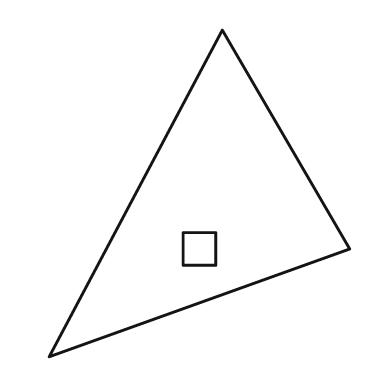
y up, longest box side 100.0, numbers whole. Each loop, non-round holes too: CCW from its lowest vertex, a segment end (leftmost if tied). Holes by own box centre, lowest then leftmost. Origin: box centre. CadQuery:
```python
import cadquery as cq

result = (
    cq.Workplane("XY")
    .moveTo(-46.0, -50.0)
    .lineTo(46.0, -17.0)
    .lineTo(7.0, 50.0)
    .close()
    .moveTo(-5.0, -22.0)
    .lineTo(5.0, -22.0)
    .lineTo(5.0, -12.0)
    .lineTo(-5.0, -12.0)
    .close()
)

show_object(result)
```